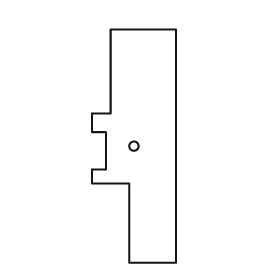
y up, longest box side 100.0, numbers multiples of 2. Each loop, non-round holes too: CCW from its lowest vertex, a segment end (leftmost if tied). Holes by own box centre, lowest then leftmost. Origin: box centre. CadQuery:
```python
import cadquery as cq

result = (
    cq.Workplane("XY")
    .moveTo(-2.0, -50.0)
    .lineTo(18.0, -50.0)
    .lineTo(18.0, 50.0)
    .lineTo(-10.0, 50.0)
    .lineTo(-10.0, 14.0)
    .lineTo(-18.0, 14.0)
    .lineTo(-18.0, 6.0)
    .lineTo(-12.0, 6.0)
    .lineTo(-12.0, -10.0)
    .lineTo(-18.0, -10.0)
    .lineTo(-18.0, -16.0)
    .lineTo(-2.0, -16.0)
    .close()
    .moveTo(0.0, 0.0)
    .circle(2.0)
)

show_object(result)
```